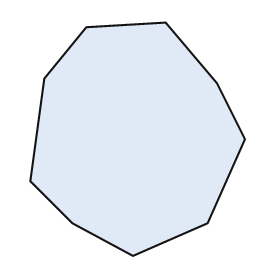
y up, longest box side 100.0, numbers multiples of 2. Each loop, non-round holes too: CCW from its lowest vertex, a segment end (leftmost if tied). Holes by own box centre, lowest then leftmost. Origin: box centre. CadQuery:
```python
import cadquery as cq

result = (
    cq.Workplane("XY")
    .moveTo(-2.0, -50.0)
    .lineTo(30.0, -36.0)
    .lineTo(46.0, 0.0)
    .lineTo(34.0, 24.0)
    .lineTo(12.0, 50.0)
    .lineTo(-22.0, 48.0)
    .lineTo(-40.0, 26.0)
    .lineTo(-46.0, -18.0)
    .lineTo(-28.0, -36.0)
    .close()
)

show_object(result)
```